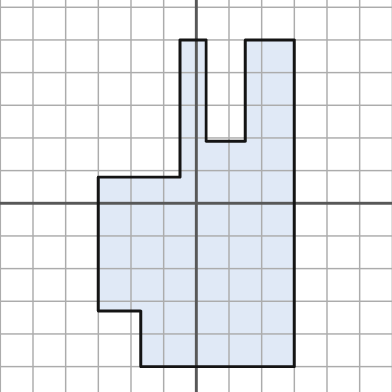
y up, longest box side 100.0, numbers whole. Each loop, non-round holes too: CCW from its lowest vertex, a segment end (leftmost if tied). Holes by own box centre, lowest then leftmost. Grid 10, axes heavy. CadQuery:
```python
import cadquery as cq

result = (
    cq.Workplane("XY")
    .moveTo(-17.0, -50.0)
    .lineTo(30.0, -50.0)
    .lineTo(30.0, 50.0)
    .lineTo(15.0, 50.0)
    .lineTo(15.0, 19.0)
    .lineTo(3.0, 19.0)
    .lineTo(3.0, 50.0)
    .lineTo(-5.0, 50.0)
    .lineTo(-5.0, 8.0)
    .lineTo(-30.0, 8.0)
    .lineTo(-30.0, -33.0)
    .lineTo(-17.0, -33.0)
    .close()
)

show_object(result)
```